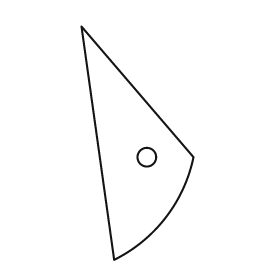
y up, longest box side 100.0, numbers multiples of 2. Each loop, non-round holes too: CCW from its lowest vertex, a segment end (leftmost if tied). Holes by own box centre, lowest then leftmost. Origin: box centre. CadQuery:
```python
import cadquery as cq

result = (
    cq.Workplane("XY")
    .moveTo(-10.0, -50.0)
    .threePointArc((12.0, -32.0), (24.0, -6.0))
    .lineTo(-24.0, 50.0)
    .close()
    .moveTo(4.0, -6.0)
    .circle(4.0)
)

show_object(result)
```